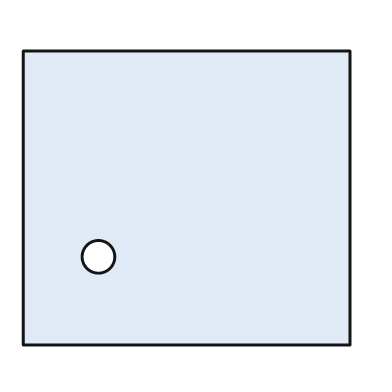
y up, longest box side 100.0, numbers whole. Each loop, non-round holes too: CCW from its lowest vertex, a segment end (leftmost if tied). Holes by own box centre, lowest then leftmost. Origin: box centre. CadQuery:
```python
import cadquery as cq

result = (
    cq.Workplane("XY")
    .moveTo(-50.0, -45.0)
    .lineTo(50.0, -45.0)
    .lineTo(50.0, 45.0)
    .lineTo(-50.0, 45.0)
    .close()
    .moveTo(-27.0, -18.0)
    .circle(5.0)
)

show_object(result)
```